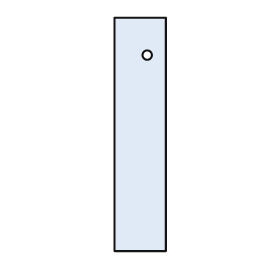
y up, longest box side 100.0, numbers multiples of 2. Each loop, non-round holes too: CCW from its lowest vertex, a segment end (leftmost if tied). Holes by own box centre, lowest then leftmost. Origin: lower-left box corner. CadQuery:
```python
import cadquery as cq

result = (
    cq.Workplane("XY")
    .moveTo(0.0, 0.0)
    .lineTo(22.0, 0.0)
    .lineTo(22.0, 100.0)
    .lineTo(0.0, 100.0)
    .close()
    .moveTo(14.0, 84.0)
    .circle(2.0)
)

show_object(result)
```